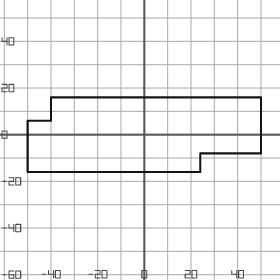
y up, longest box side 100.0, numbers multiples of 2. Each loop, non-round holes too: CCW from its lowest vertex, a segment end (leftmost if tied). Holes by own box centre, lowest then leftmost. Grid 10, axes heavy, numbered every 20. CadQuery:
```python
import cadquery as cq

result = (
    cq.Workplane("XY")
    .moveTo(-50.0, -16.0)
    .lineTo(24.0, -16.0)
    .lineTo(24.0, -8.0)
    .lineTo(50.0, -8.0)
    .lineTo(50.0, 16.0)
    .lineTo(-40.0, 16.0)
    .lineTo(-40.0, 6.0)
    .lineTo(-50.0, 6.0)
    .close()
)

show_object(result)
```